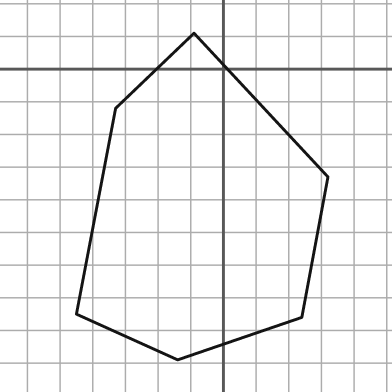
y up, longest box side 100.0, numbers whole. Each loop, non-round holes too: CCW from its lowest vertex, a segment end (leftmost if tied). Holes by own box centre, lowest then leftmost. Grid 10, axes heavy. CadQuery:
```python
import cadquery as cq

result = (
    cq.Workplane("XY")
    .moveTo(-14.0, -89.0)
    .lineTo(24.0, -76.0)
    .lineTo(32.0, -33.0)
    .lineTo(-9.0, 11.0)
    .lineTo(-33.0, -12.0)
    .lineTo(-45.0, -75.0)
    .close()
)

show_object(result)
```